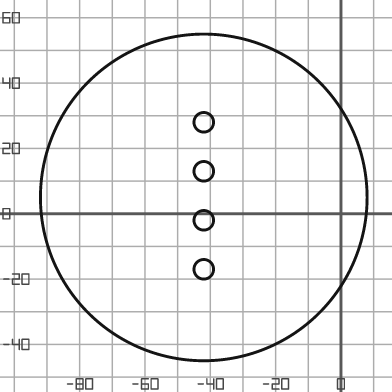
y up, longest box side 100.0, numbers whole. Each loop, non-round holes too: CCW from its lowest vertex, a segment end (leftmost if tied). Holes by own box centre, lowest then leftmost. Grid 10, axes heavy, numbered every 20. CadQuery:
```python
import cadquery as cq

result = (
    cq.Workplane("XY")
    .moveTo(-42.0, 5.0)
    .circle(50.0)
    .moveTo(-42.0, -17.0)
    .circle(3.0)
    .moveTo(-42.0, -2.0)
    .circle(3.0)
    .moveTo(-42.0, 13.0)
    .circle(3.0)
    .moveTo(-42.0, 28.0)
    .circle(3.0)
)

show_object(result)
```